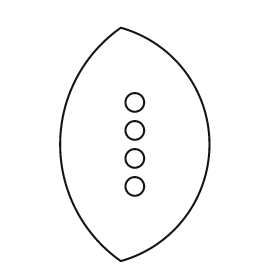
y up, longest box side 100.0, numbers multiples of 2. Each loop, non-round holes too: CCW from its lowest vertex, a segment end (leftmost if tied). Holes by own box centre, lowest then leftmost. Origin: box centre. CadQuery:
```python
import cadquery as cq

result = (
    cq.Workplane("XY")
    .moveTo(-6.0, -50.0)
    .threePointArc((32.0, 0.0), (-6.0, 50.0))
    .threePointArc((-32.0, 0.0), (-6.0, -50.0))
    .close()
    .moveTo(0.0, -18.0)
    .circle(4.0)
    .moveTo(0.0, -6.0)
    .circle(4.0)
    .moveTo(0.0, 6.0)
    .circle(4.0)
    .moveTo(0.0, 18.0)
    .circle(4.0)
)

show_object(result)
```